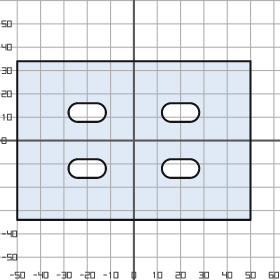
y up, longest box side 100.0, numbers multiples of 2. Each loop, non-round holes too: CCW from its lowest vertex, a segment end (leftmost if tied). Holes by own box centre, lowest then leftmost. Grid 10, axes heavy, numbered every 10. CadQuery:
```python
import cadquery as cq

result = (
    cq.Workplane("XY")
    .moveTo(-50.0, -34.0)
    .lineTo(50.0, -34.0)
    .lineTo(50.0, 34.0)
    .lineTo(-50.0, 34.0)
    .close()
    .moveTo(-24.0, -16.0)
    .lineTo(-16.0, -16.0)
    .threePointArc((-12.0, -12.0), (-16.0, -8.0))
    .lineTo(-24.0, -8.0)
    .threePointArc((-28.0, -12.0), (-24.0, -16.0))
    .close()
    .moveTo(16.0, -16.0)
    .lineTo(24.0, -16.0)
    .threePointArc((28.0, -12.0), (24.0, -8.0))
    .lineTo(16.0, -8.0)
    .threePointArc((12.0, -12.0), (16.0, -16.0))
    .close()
    .moveTo(-24.0, 8.0)
    .lineTo(-16.0, 8.0)
    .threePointArc((-12.0, 12.0), (-16.0, 16.0))
    .lineTo(-24.0, 16.0)
    .threePointArc((-28.0, 12.0), (-24.0, 8.0))
    .close()
    .moveTo(16.0, 8.0)
    .lineTo(24.0, 8.0)
    .threePointArc((28.0, 12.0), (24.0, 16.0))
    .lineTo(16.0, 16.0)
    .threePointArc((12.0, 12.0), (16.0, 8.0))
    .close()
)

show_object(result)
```